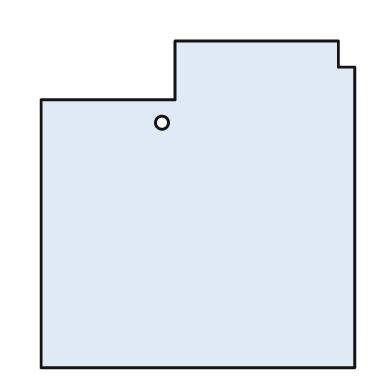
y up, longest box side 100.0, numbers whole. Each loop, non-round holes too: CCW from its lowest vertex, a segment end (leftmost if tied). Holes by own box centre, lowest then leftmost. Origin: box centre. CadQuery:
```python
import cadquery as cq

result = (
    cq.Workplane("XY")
    .moveTo(-48.0, -50.0)
    .lineTo(48.0, -50.0)
    .lineTo(48.0, 42.0)
    .lineTo(43.0, 42.0)
    .lineTo(43.0, 50.0)
    .lineTo(-7.0, 50.0)
    .lineTo(-7.0, 32.0)
    .lineTo(-48.0, 32.0)
    .close()
    .moveTo(-11.0, 25.0)
    .circle(2.0)
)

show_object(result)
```